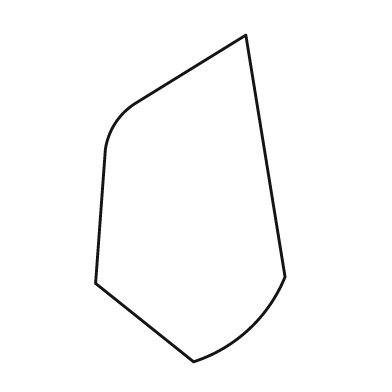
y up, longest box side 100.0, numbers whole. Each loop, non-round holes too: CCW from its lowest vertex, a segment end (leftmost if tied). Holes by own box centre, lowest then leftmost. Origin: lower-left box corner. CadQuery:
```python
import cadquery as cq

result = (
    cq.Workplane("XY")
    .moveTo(30.0, 0.0)
    .threePointArc((47.0, 10.0), (58.0, 26.0))
    .lineTo(46.0, 100.0)
    .lineTo(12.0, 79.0)
    .threePointArc((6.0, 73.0), (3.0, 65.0))
    .lineTo(0.0, 24.0)
    .close()
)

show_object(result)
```